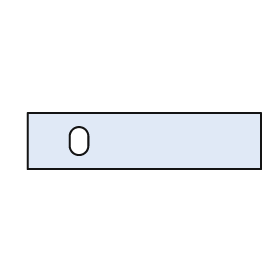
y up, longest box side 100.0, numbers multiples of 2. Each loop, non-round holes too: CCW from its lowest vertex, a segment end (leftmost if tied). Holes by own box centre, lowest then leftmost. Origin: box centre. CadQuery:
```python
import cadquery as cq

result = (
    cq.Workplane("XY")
    .moveTo(-50.0, -12.0)
    .lineTo(50.0, -12.0)
    .lineTo(50.0, 12.0)
    .lineTo(-50.0, 12.0)
    .close()
    .moveTo(-32.0, -2.0)
    .threePointArc((-28.0, -6.0), (-24.0, -2.0))
    .lineTo(-24.0, 2.0)
    .threePointArc((-28.0, 6.0), (-32.0, 2.0))
    .close()
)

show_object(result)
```